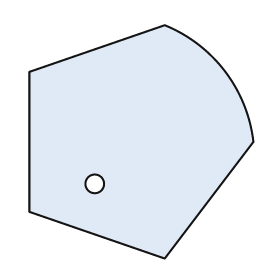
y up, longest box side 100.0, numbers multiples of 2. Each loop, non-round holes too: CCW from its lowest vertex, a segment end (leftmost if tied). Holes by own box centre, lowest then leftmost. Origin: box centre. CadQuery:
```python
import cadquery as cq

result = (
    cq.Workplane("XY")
    .moveTo(10.0, -50.0)
    .lineTo(48.0, 0.0)
    .threePointArc((36.0, 30.0), (10.0, 50.0))
    .lineTo(-48.0, 30.0)
    .lineTo(-48.0, -30.0)
    .close()
    .moveTo(-20.0, -18.0)
    .circle(4.0)
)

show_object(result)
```